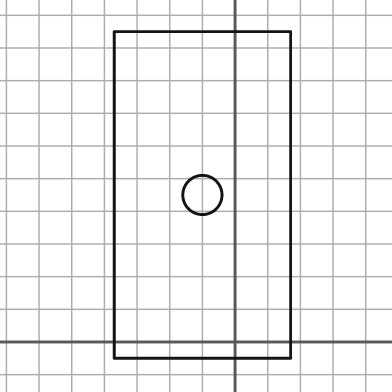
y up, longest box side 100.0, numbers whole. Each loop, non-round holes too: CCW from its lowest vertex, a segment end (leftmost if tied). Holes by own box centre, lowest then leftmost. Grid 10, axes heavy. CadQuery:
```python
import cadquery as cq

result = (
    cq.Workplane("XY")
    .moveTo(-37.0, -5.0)
    .lineTo(17.0, -5.0)
    .lineTo(17.0, 95.0)
    .lineTo(-37.0, 95.0)
    .close()
    .moveTo(-10.0, 45.0)
    .circle(6.0)
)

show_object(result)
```